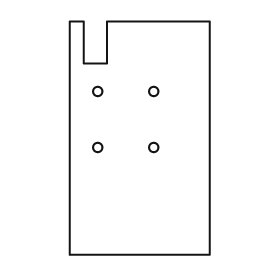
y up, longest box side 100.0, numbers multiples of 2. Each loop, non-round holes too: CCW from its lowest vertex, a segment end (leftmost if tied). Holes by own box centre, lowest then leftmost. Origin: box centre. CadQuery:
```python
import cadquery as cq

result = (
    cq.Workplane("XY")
    .moveTo(-30.0, -50.0)
    .lineTo(30.0, -50.0)
    .lineTo(30.0, 50.0)
    .lineTo(-14.0, 50.0)
    .lineTo(-14.0, 32.0)
    .lineTo(-24.0, 32.0)
    .lineTo(-24.0, 50.0)
    .lineTo(-30.0, 50.0)
    .close()
    .moveTo(-18.0, -4.0)
    .circle(2.0)
    .moveTo(6.0, -4.0)
    .circle(2.0)
    .moveTo(-18.0, 20.0)
    .circle(2.0)
    .moveTo(6.0, 20.0)
    .circle(2.0)
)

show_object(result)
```